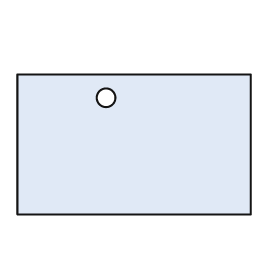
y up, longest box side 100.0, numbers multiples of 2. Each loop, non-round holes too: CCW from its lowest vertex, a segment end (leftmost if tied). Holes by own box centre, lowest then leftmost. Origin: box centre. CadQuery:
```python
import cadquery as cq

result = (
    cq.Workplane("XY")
    .moveTo(-50.0, -30.0)
    .lineTo(50.0, -30.0)
    .lineTo(50.0, 30.0)
    .lineTo(-50.0, 30.0)
    .close()
    .moveTo(-12.0, 20.0)
    .circle(4.0)
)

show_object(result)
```